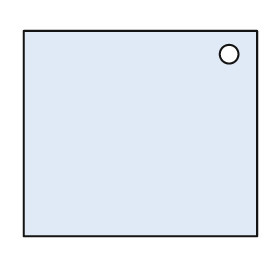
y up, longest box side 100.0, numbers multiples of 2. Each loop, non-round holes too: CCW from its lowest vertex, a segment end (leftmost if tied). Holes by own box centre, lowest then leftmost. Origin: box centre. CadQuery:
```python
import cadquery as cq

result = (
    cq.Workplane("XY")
    .moveTo(-50.0, -44.0)
    .lineTo(50.0, -44.0)
    .lineTo(50.0, 44.0)
    .lineTo(-50.0, 44.0)
    .close()
    .moveTo(38.0, 34.0)
    .circle(4.0)
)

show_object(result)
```